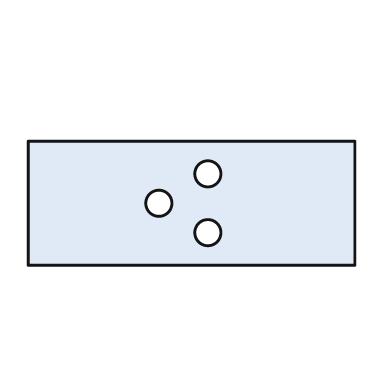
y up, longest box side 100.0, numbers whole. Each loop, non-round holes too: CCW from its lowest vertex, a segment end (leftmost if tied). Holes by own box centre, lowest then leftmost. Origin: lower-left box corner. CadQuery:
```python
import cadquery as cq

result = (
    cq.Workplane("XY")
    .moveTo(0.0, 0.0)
    .lineTo(100.0, 0.0)
    .lineTo(100.0, 38.0)
    .lineTo(0.0, 38.0)
    .close()
    .moveTo(55.0, 10.0)
    .circle(4.0)
    .moveTo(40.0, 19.0)
    .circle(4.0)
    .moveTo(55.0, 28.0)
    .circle(4.0)
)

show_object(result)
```